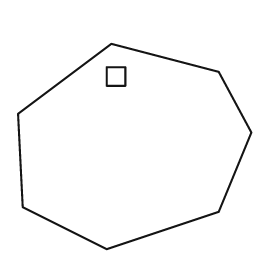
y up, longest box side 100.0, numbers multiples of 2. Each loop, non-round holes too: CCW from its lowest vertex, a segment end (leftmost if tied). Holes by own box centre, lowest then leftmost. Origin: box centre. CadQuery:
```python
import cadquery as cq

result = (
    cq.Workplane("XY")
    .moveTo(-12.0, -44.0)
    .lineTo(36.0, -28.0)
    .lineTo(50.0, 6.0)
    .lineTo(36.0, 32.0)
    .lineTo(-10.0, 44.0)
    .lineTo(-50.0, 14.0)
    .lineTo(-48.0, -26.0)
    .close()
    .moveTo(-12.0, 26.0)
    .lineTo(-4.0, 26.0)
    .lineTo(-4.0, 34.0)
    .lineTo(-12.0, 34.0)
    .close()
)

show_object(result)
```